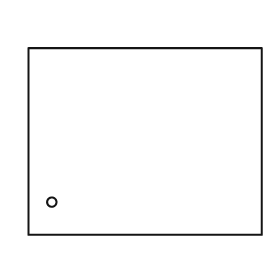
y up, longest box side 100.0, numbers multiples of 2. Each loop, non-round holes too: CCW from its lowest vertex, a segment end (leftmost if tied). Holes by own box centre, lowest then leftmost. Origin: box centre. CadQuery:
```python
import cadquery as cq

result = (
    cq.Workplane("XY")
    .moveTo(-50.0, -40.0)
    .lineTo(50.0, -40.0)
    .lineTo(50.0, 40.0)
    .lineTo(-50.0, 40.0)
    .close()
    .moveTo(-40.0, -26.0)
    .circle(2.0)
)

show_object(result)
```